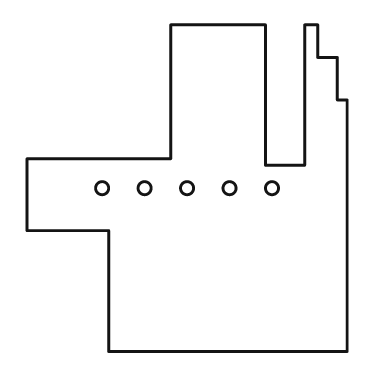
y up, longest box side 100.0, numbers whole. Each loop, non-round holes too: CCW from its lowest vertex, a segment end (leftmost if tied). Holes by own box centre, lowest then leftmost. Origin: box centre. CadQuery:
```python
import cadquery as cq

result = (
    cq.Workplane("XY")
    .moveTo(-24.0, -50.0)
    .lineTo(49.0, -50.0)
    .lineTo(49.0, 27.0)
    .lineTo(46.0, 27.0)
    .lineTo(46.0, 40.0)
    .lineTo(40.0, 40.0)
    .lineTo(40.0, 50.0)
    .lineTo(36.0, 50.0)
    .lineTo(36.0, 7.0)
    .lineTo(24.0, 7.0)
    .lineTo(24.0, 50.0)
    .lineTo(-5.0, 50.0)
    .lineTo(-5.0, 9.0)
    .lineTo(-49.0, 9.0)
    .lineTo(-49.0, -13.0)
    .lineTo(-24.0, -13.0)
    .close()
    .moveTo(-26.0, 0.0)
    .circle(2.0)
    .moveTo(-13.0, 0.0)
    .circle(2.0)
    .moveTo(0.0, 0.0)
    .circle(2.0)
    .moveTo(13.0, 0.0)
    .circle(2.0)
    .moveTo(26.0, 0.0)
    .circle(2.0)
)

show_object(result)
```